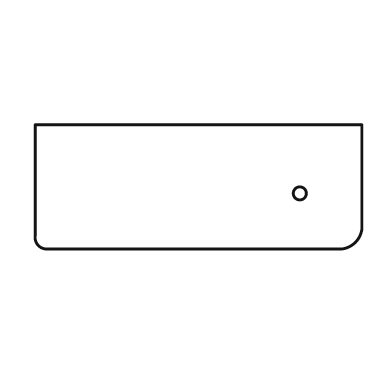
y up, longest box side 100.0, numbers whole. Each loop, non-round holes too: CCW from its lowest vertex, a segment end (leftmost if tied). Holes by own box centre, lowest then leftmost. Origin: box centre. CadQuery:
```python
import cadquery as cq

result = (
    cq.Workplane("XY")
    .moveTo(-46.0, -19.0)
    .lineTo(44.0, -19.0)
    .threePointArc((48.0, -17.0), (50.0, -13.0))
    .lineTo(50.0, 19.0)
    .lineTo(-50.0, 19.0)
    .lineTo(-50.0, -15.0)
    .threePointArc((-49.0, -18.0), (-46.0, -19.0))
    .close()
    .moveTo(31.0, -2.0)
    .circle(2.0)
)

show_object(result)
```